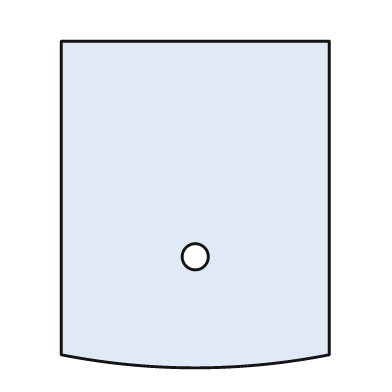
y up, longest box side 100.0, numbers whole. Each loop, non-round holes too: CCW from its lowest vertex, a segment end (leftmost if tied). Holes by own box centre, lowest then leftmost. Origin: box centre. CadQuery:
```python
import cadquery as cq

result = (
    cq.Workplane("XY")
    .moveTo(-41.0, -46.0)
    .threePointArc((0.0, -50.0), (41.0, -46.0))
    .lineTo(41.0, 50.0)
    .lineTo(-41.0, 50.0)
    .close()
    .moveTo(0.0, -16.0)
    .circle(4.0)
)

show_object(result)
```